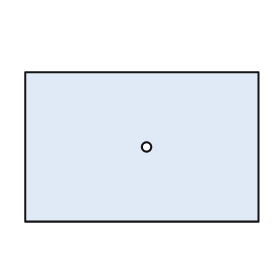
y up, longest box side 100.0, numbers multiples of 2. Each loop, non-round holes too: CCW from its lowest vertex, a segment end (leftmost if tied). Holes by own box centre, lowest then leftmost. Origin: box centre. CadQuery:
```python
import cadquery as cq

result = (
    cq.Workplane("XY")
    .moveTo(-50.0, -32.0)
    .lineTo(50.0, -32.0)
    .lineTo(50.0, 32.0)
    .lineTo(-50.0, 32.0)
    .close()
    .moveTo(2.0, 0.0)
    .circle(2.0)
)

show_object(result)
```